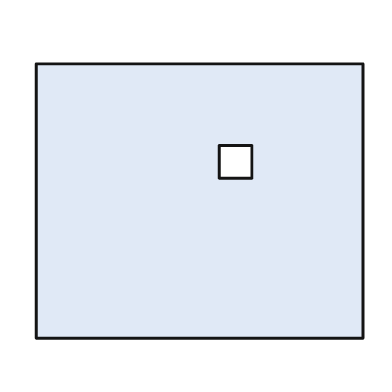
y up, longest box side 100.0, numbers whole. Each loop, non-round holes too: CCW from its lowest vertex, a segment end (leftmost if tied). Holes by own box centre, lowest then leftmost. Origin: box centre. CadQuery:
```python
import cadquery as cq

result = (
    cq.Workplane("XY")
    .moveTo(-50.0, -42.0)
    .lineTo(50.0, -42.0)
    .lineTo(50.0, 42.0)
    .lineTo(-50.0, 42.0)
    .close()
    .moveTo(6.0, 7.0)
    .lineTo(16.0, 7.0)
    .lineTo(16.0, 17.0)
    .lineTo(6.0, 17.0)
    .close()
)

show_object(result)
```